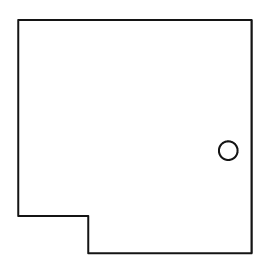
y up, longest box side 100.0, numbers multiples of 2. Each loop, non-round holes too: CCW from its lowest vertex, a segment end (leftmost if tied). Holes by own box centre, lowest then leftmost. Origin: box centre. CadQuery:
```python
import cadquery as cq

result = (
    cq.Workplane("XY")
    .moveTo(-20.0, -50.0)
    .lineTo(50.0, -50.0)
    .lineTo(50.0, 50.0)
    .lineTo(-50.0, 50.0)
    .lineTo(-50.0, -34.0)
    .lineTo(-20.0, -34.0)
    .close()
    .moveTo(40.0, -6.0)
    .circle(4.0)
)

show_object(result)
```